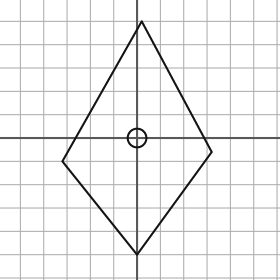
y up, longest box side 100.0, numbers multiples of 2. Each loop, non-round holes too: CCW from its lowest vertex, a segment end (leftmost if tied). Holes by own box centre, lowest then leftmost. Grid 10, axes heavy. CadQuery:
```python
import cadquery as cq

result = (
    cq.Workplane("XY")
    .moveTo(0.0, -50.0)
    .lineTo(32.0, -6.0)
    .lineTo(2.0, 50.0)
    .lineTo(-32.0, -10.0)
    .close()
    .moveTo(0.0, 0.0)
    .circle(4.0)
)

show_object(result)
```